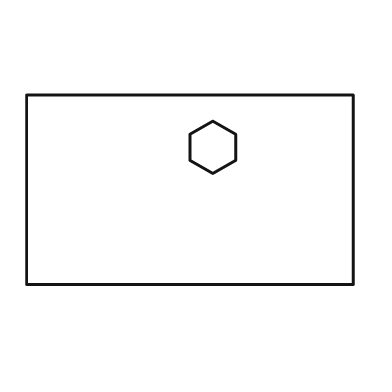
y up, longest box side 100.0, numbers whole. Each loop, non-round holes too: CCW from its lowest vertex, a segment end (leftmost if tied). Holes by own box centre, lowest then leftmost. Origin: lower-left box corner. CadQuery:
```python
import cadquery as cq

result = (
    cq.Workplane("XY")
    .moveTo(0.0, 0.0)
    .lineTo(100.0, 0.0)
    .lineTo(100.0, 58.0)
    .lineTo(0.0, 58.0)
    .close()
    .moveTo(57.0, 34.0)
    .lineTo(64.0, 38.0)
    .lineTo(64.0, 46.0)
    .lineTo(57.0, 50.0)
    .lineTo(50.0, 46.0)
    .lineTo(50.0, 38.0)
    .close()
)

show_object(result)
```